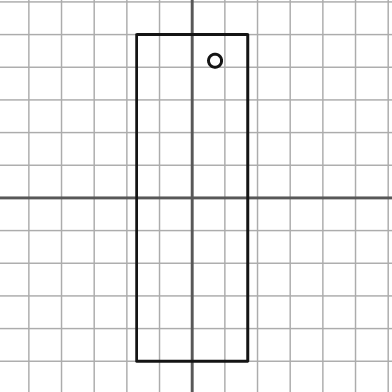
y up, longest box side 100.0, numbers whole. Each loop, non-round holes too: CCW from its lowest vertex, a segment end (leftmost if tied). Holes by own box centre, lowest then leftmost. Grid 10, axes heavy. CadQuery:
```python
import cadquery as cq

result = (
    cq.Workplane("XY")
    .moveTo(-17.0, -50.0)
    .lineTo(17.0, -50.0)
    .lineTo(17.0, 50.0)
    .lineTo(-17.0, 50.0)
    .close()
    .moveTo(7.0, 42.0)
    .circle(2.0)
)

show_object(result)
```